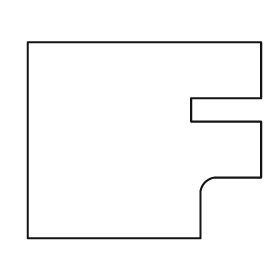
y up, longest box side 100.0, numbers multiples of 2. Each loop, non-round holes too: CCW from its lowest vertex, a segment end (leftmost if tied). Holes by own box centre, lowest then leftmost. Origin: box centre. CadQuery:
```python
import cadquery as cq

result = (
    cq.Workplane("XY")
    .moveTo(-50.0, -42.0)
    .lineTo(24.0, -42.0)
    .lineTo(24.0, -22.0)
    .threePointArc((26.0, -18.0), (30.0, -16.0))
    .lineTo(50.0, -16.0)
    .lineTo(50.0, 8.0)
    .lineTo(20.0, 8.0)
    .lineTo(20.0, 18.0)
    .lineTo(50.0, 18.0)
    .lineTo(50.0, 42.0)
    .lineTo(-50.0, 42.0)
    .close()
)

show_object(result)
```